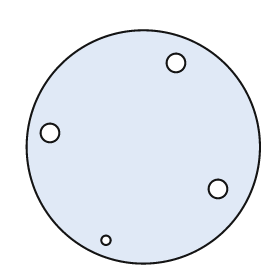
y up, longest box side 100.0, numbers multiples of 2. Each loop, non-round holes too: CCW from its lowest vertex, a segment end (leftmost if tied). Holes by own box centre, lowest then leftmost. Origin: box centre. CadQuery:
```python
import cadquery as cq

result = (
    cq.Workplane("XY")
    .moveTo(0.0, 0.0)
    .circle(50.0)
    .moveTo(-16.0, -40.0)
    .circle(2.0)
    .moveTo(32.0, -18.0)
    .circle(4.0)
    .moveTo(-40.0, 6.0)
    .circle(4.0)
    .moveTo(14.0, 36.0)
    .circle(4.0)
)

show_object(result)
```